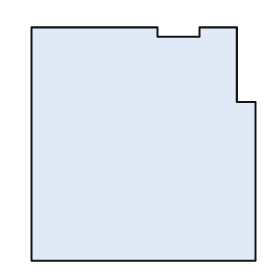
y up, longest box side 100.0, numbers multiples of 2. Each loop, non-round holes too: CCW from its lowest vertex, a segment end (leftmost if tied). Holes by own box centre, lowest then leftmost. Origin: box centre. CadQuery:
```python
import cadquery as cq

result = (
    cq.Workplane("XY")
    .moveTo(-48.0, -50.0)
    .lineTo(48.0, -50.0)
    .lineTo(48.0, 18.0)
    .lineTo(40.0, 18.0)
    .lineTo(40.0, 50.0)
    .lineTo(24.0, 50.0)
    .lineTo(24.0, 46.0)
    .lineTo(6.0, 46.0)
    .lineTo(6.0, 50.0)
    .lineTo(-48.0, 50.0)
    .close()
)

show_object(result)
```